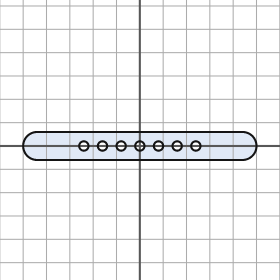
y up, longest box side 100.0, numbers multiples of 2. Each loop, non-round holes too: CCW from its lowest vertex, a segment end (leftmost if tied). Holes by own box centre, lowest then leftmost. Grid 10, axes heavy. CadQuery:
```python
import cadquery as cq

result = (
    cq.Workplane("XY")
    .moveTo(-44.0, -6.0)
    .lineTo(44.0, -6.0)
    .threePointArc((50.0, 0.0), (44.0, 6.0))
    .lineTo(-44.0, 6.0)
    .threePointArc((-50.0, 0.0), (-44.0, -6.0))
    .close()
    .moveTo(-24.0, 0.0)
    .circle(2.0)
    .moveTo(-16.0, 0.0)
    .circle(2.0)
    .moveTo(-8.0, 0.0)
    .circle(2.0)
    .moveTo(0.0, 0.0)
    .circle(2.0)
    .moveTo(8.0, 0.0)
    .circle(2.0)
    .moveTo(16.0, 0.0)
    .circle(2.0)
    .moveTo(24.0, 0.0)
    .circle(2.0)
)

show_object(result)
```